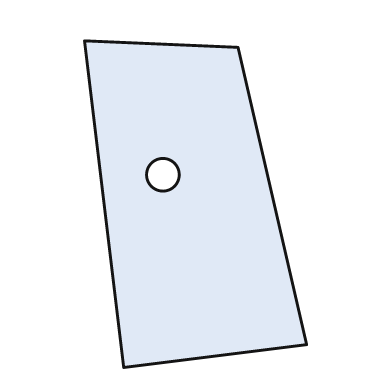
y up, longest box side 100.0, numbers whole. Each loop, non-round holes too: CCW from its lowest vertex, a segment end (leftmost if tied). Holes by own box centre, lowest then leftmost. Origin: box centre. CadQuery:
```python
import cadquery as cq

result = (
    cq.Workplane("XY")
    .moveTo(-22.0, -50.0)
    .lineTo(34.0, -43.0)
    .lineTo(13.0, 48.0)
    .lineTo(-34.0, 50.0)
    .close()
    .moveTo(-10.0, 9.0)
    .circle(5.0)
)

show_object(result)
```